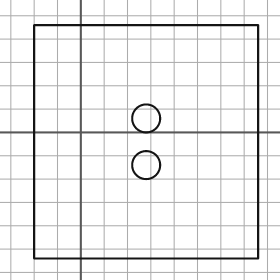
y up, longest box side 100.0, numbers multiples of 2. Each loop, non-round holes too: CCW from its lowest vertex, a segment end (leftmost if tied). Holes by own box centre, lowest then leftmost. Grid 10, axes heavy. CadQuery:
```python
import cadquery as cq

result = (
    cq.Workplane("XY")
    .moveTo(-20.0, -54.0)
    .lineTo(76.0, -54.0)
    .lineTo(76.0, 46.0)
    .lineTo(-20.0, 46.0)
    .close()
    .moveTo(28.0, -14.0)
    .circle(6.0)
    .moveTo(28.0, 6.0)
    .circle(6.0)
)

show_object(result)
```